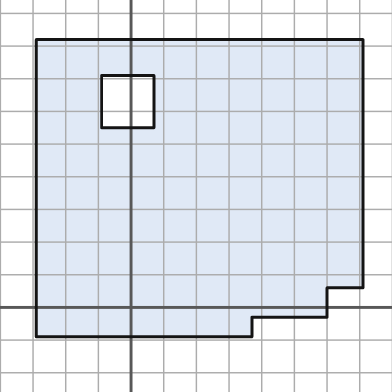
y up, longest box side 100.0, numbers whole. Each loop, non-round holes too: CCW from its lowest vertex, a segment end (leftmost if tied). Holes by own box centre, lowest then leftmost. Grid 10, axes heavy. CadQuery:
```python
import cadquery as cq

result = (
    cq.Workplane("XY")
    .moveTo(-29.0, -9.0)
    .lineTo(37.0, -9.0)
    .lineTo(37.0, -3.0)
    .lineTo(60.0, -3.0)
    .lineTo(60.0, 6.0)
    .lineTo(71.0, 6.0)
    .lineTo(71.0, 82.0)
    .lineTo(-29.0, 82.0)
    .close()
    .moveTo(-9.0, 55.0)
    .lineTo(7.0, 55.0)
    .lineTo(7.0, 71.0)
    .lineTo(-9.0, 71.0)
    .close()
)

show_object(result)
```